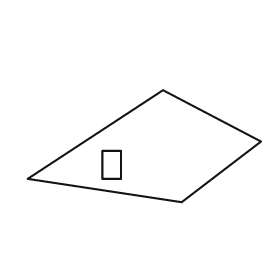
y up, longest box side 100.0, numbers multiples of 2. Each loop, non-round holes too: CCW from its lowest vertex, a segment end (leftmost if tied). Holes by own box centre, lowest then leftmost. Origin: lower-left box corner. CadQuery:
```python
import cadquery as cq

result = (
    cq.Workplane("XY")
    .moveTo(66.0, 0.0)
    .lineTo(100.0, 26.0)
    .lineTo(58.0, 48.0)
    .lineTo(0.0, 10.0)
    .close()
    .moveTo(32.0, 10.0)
    .lineTo(40.0, 10.0)
    .lineTo(40.0, 22.0)
    .lineTo(32.0, 22.0)
    .close()
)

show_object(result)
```